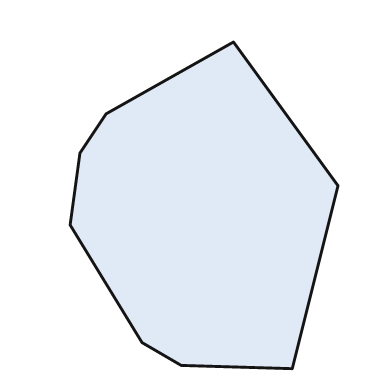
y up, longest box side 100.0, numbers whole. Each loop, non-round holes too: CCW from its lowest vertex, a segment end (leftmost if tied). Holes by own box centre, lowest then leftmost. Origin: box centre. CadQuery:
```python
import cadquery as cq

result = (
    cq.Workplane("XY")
    .moveTo(27.0, -50.0)
    .lineTo(41.0, 6.0)
    .lineTo(9.0, 50.0)
    .lineTo(-30.0, 28.0)
    .lineTo(-38.0, 16.0)
    .lineTo(-41.0, -6.0)
    .lineTo(-19.0, -42.0)
    .lineTo(-7.0, -49.0)
    .close()
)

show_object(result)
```